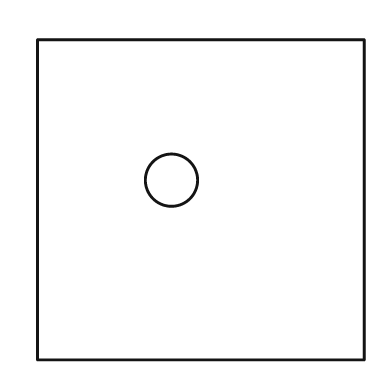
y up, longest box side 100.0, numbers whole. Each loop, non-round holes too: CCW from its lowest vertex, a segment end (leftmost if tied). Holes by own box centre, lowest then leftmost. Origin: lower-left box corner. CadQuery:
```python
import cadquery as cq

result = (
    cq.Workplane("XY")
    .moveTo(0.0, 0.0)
    .lineTo(100.0, 0.0)
    .lineTo(100.0, 98.0)
    .lineTo(0.0, 98.0)
    .close()
    .moveTo(41.0, 55.0)
    .circle(8.0)
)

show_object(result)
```